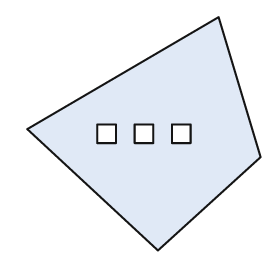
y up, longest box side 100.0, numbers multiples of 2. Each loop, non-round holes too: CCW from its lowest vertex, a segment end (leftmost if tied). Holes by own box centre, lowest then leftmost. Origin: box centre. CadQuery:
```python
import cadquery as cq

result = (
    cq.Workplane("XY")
    .moveTo(6.0, -50.0)
    .lineTo(50.0, -10.0)
    .lineTo(32.0, 50.0)
    .lineTo(-50.0, 2.0)
    .close()
    .moveTo(-20.0, -4.0)
    .lineTo(-12.0, -4.0)
    .lineTo(-12.0, 4.0)
    .lineTo(-20.0, 4.0)
    .close()
    .moveTo(-4.0, -4.0)
    .lineTo(4.0, -4.0)
    .lineTo(4.0, 4.0)
    .lineTo(-4.0, 4.0)
    .close()
    .moveTo(12.0, -4.0)
    .lineTo(20.0, -4.0)
    .lineTo(20.0, 4.0)
    .lineTo(12.0, 4.0)
    .close()
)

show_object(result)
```